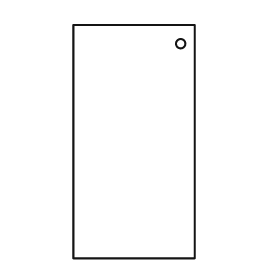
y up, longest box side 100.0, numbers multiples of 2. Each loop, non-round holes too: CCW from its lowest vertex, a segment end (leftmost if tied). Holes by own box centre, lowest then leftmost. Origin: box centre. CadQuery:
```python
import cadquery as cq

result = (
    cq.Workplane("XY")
    .moveTo(-26.0, -50.0)
    .lineTo(26.0, -50.0)
    .lineTo(26.0, 50.0)
    .lineTo(-26.0, 50.0)
    .close()
    .moveTo(20.0, 42.0)
    .circle(2.0)
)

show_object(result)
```